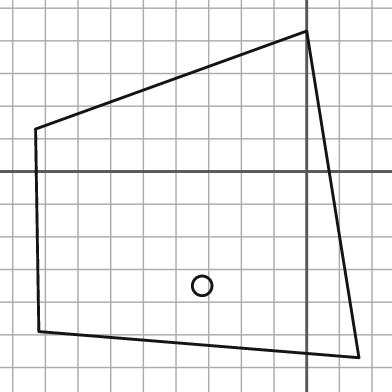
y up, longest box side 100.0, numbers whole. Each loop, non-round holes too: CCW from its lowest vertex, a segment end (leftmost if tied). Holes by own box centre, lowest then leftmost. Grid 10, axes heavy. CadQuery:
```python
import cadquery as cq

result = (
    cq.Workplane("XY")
    .moveTo(16.0, -57.0)
    .lineTo(0.0, 43.0)
    .lineTo(-83.0, 13.0)
    .lineTo(-82.0, -49.0)
    .close()
    .moveTo(-32.0, -35.0)
    .circle(3.0)
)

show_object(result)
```